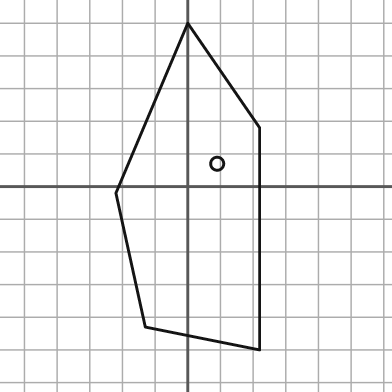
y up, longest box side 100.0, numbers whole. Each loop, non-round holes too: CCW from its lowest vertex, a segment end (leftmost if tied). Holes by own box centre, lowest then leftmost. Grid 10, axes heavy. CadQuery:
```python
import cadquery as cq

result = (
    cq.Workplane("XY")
    .moveTo(22.0, -50.0)
    .lineTo(22.0, 18.0)
    .lineTo(0.0, 50.0)
    .lineTo(-22.0, -2.0)
    .lineTo(-13.0, -43.0)
    .close()
    .moveTo(9.0, 7.0)
    .circle(2.0)
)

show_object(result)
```